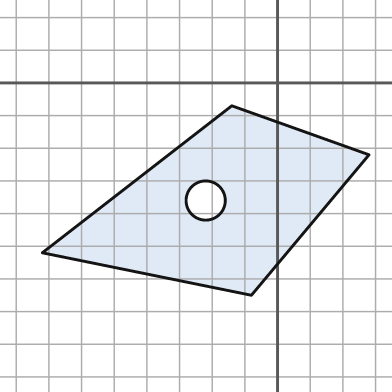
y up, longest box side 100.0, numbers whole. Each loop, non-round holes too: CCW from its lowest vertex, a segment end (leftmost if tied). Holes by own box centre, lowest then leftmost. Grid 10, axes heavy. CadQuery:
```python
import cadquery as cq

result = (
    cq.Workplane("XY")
    .moveTo(-8.0, -65.0)
    .lineTo(28.0, -22.0)
    .lineTo(-14.0, -7.0)
    .lineTo(-72.0, -52.0)
    .close()
    .moveTo(-22.0, -36.0)
    .circle(6.0)
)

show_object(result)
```